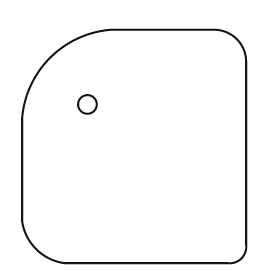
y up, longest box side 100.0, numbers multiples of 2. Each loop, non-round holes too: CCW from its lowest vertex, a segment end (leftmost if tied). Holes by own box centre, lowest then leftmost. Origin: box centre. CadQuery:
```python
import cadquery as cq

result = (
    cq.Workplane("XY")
    .moveTo(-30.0, -50.0)
    .lineTo(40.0, -50.0)
    .threePointArc((46.0, -48.0), (48.0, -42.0))
    .lineTo(48.0, 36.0)
    .threePointArc((44.0, 46.0), (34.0, 50.0))
    .lineTo(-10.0, 50.0)
    .threePointArc((-36.0, 38.0), (-48.0, 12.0))
    .lineTo(-48.0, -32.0)
    .threePointArc((-42.0, -44.0), (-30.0, -50.0))
    .close()
    .moveTo(-20.0, 18.0)
    .circle(4.0)
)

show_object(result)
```